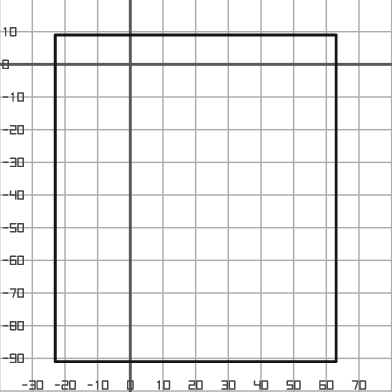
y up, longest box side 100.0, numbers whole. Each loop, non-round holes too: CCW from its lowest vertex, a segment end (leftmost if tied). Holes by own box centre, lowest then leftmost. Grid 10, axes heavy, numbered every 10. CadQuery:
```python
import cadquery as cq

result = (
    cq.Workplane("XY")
    .moveTo(-23.0, -91.0)
    .lineTo(63.0, -91.0)
    .lineTo(63.0, 9.0)
    .lineTo(-23.0, 9.0)
    .close()
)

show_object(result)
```